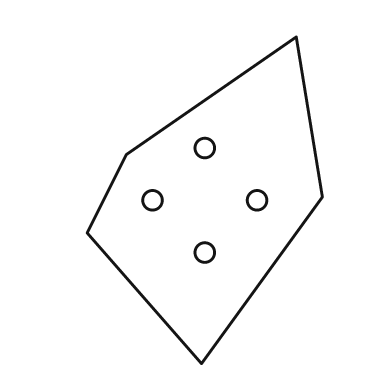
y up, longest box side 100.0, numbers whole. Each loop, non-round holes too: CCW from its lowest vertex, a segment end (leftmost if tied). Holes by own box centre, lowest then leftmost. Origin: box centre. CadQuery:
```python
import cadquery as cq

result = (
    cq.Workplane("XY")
    .moveTo(-1.0, -50.0)
    .lineTo(36.0, 1.0)
    .lineTo(28.0, 50.0)
    .lineTo(-24.0, 14.0)
    .lineTo(-36.0, -10.0)
    .close()
    .moveTo(0.0, -16.0)
    .circle(3.0)
    .moveTo(-16.0, 0.0)
    .circle(3.0)
    .moveTo(16.0, 0.0)
    .circle(3.0)
    .moveTo(0.0, 16.0)
    .circle(3.0)
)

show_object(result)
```